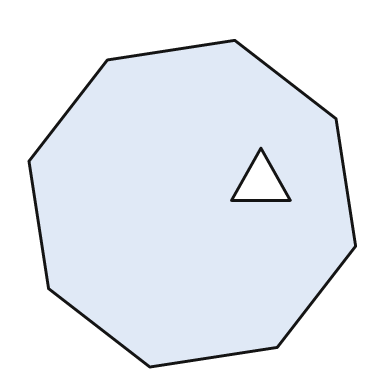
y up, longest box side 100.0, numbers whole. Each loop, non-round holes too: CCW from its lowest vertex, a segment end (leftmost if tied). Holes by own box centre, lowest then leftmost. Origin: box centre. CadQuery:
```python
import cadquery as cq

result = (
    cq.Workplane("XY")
    .moveTo(-13.0, -50.0)
    .lineTo(26.0, -44.0)
    .lineTo(50.0, -13.0)
    .lineTo(44.0, 26.0)
    .lineTo(13.0, 50.0)
    .lineTo(-26.0, 44.0)
    .lineTo(-50.0, 13.0)
    .lineTo(-44.0, -26.0)
    .close()
    .moveTo(12.0, 1.0)
    .lineTo(30.0, 1.0)
    .lineTo(21.0, 17.0)
    .close()
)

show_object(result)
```